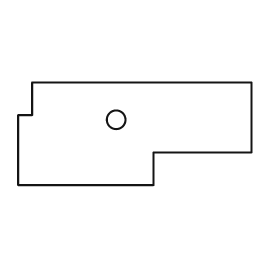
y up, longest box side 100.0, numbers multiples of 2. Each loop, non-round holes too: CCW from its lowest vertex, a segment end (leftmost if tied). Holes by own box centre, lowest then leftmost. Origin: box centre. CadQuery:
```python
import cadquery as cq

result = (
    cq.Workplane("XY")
    .moveTo(-50.0, -22.0)
    .lineTo(8.0, -22.0)
    .lineTo(8.0, -8.0)
    .lineTo(50.0, -8.0)
    .lineTo(50.0, 22.0)
    .lineTo(-44.0, 22.0)
    .lineTo(-44.0, 8.0)
    .lineTo(-50.0, 8.0)
    .close()
    .moveTo(-8.0, 6.0)
    .circle(4.0)
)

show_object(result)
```